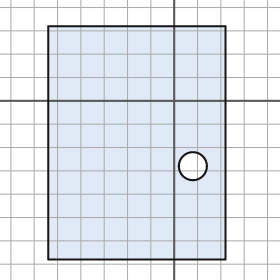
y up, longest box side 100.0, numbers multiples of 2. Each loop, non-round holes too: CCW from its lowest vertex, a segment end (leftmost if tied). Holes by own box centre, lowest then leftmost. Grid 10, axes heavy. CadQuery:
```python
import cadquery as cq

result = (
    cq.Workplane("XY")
    .moveTo(-54.0, -68.0)
    .lineTo(22.0, -68.0)
    .lineTo(22.0, 32.0)
    .lineTo(-54.0, 32.0)
    .close()
    .moveTo(8.0, -28.0)
    .circle(6.0)
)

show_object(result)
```